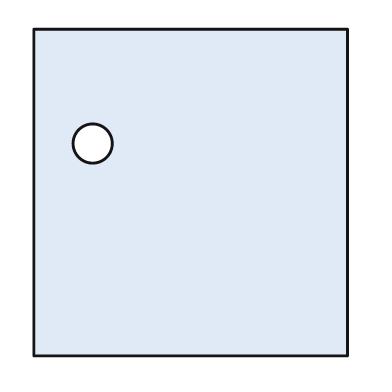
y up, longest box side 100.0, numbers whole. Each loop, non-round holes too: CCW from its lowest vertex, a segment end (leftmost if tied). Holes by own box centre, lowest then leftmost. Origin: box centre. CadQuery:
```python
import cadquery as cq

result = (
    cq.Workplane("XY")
    .moveTo(-48.0, -50.0)
    .lineTo(48.0, -50.0)
    .lineTo(48.0, 50.0)
    .lineTo(-48.0, 50.0)
    .close()
    .moveTo(-30.0, 15.0)
    .circle(6.0)
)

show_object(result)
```